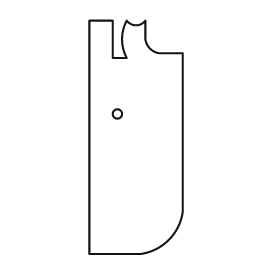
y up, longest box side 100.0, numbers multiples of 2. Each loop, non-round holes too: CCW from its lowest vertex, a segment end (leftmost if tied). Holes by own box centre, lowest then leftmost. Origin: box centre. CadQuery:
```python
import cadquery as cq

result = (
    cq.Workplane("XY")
    .moveTo(-20.0, -50.0)
    .lineTo(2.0, -50.0)
    .threePointArc((14.0, -44.0), (20.0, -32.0))
    .lineTo(20.0, 36.0)
    .lineTo(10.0, 36.0)
    .threePointArc((6.0, 38.0), (4.0, 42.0))
    .lineTo(4.0, 50.0)
    .threePointArc((0.0, 48.0), (-4.0, 50.0))
    .threePointArc((-6.0, 42.0), (-4.0, 34.0))
    .lineTo(-10.0, 34.0)
    .lineTo(-10.0, 50.0)
    .lineTo(-20.0, 50.0)
    .close()
    .moveTo(-8.0, 10.0)
    .circle(2.0)
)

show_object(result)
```